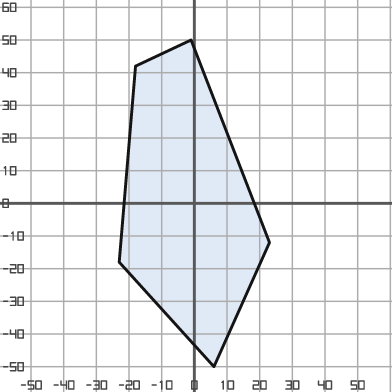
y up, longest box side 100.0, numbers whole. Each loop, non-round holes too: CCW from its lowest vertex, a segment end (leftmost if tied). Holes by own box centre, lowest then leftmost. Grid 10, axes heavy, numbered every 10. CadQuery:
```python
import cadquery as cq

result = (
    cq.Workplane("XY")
    .moveTo(6.0, -50.0)
    .lineTo(23.0, -12.0)
    .lineTo(-1.0, 50.0)
    .lineTo(-18.0, 42.0)
    .lineTo(-23.0, -18.0)
    .close()
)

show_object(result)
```